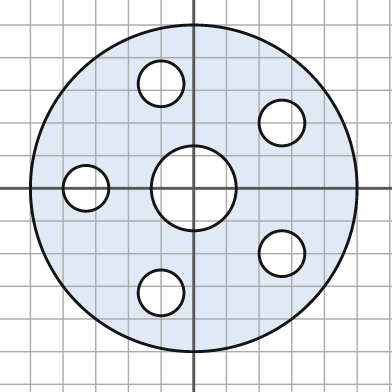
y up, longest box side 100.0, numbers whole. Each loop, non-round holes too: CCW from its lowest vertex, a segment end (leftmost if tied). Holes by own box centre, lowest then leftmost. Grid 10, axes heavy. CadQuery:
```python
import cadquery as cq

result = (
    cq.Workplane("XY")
    .moveTo(0.0, 0.0)
    .circle(50.0)
    .moveTo(-10.0, -32.0)
    .circle(7.0)
    .moveTo(27.0, -20.0)
    .circle(7.0)
    .moveTo(-33.0, 0.0)
    .circle(7.0)
    .moveTo(0.0, 0.0)
    .circle(13.0)
    .moveTo(27.0, 20.0)
    .circle(7.0)
    .moveTo(-10.0, 32.0)
    .circle(7.0)
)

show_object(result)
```